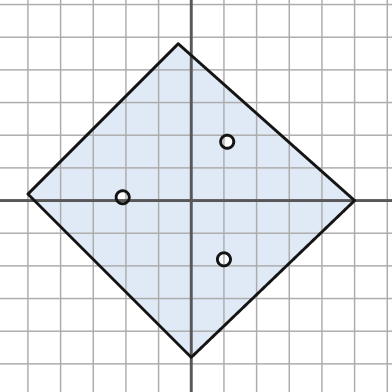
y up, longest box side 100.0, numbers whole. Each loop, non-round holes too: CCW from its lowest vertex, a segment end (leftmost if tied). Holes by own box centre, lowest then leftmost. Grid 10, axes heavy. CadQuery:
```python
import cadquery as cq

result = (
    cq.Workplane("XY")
    .moveTo(0.0, -48.0)
    .lineTo(50.0, 0.0)
    .lineTo(-4.0, 48.0)
    .lineTo(-50.0, 2.0)
    .close()
    .moveTo(10.0, -18.0)
    .circle(2.0)
    .moveTo(-21.0, 1.0)
    .circle(2.0)
    .moveTo(11.0, 18.0)
    .circle(2.0)
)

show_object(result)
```